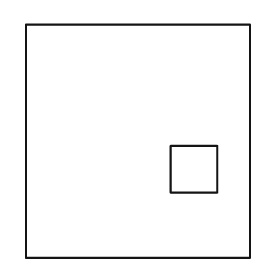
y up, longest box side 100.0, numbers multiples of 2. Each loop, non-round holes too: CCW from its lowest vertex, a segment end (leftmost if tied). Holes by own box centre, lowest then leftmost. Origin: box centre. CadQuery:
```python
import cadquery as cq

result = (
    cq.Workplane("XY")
    .moveTo(-48.0, -50.0)
    .lineTo(48.0, -50.0)
    .lineTo(48.0, 50.0)
    .lineTo(-48.0, 50.0)
    .close()
    .moveTo(14.0, -22.0)
    .lineTo(34.0, -22.0)
    .lineTo(34.0, -2.0)
    .lineTo(14.0, -2.0)
    .close()
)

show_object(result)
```